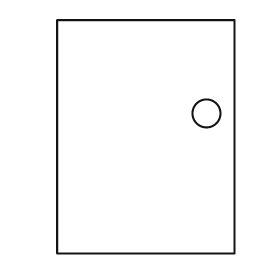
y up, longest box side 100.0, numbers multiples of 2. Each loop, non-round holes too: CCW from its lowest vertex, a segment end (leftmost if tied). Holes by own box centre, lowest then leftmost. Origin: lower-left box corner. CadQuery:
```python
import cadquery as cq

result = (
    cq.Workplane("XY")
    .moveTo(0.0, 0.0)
    .lineTo(76.0, 0.0)
    .lineTo(76.0, 100.0)
    .lineTo(0.0, 100.0)
    .close()
    .moveTo(64.0, 60.0)
    .circle(6.0)
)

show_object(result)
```